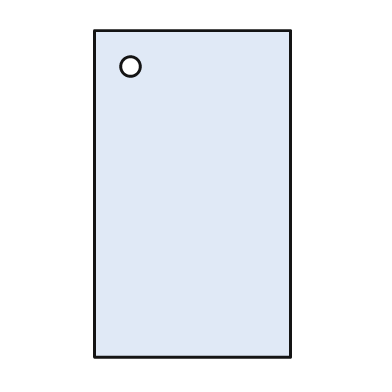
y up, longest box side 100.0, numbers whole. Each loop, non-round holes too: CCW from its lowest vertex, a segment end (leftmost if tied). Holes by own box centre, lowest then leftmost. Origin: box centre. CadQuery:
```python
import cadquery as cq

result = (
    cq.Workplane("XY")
    .moveTo(-30.0, -50.0)
    .lineTo(30.0, -50.0)
    .lineTo(30.0, 50.0)
    .lineTo(-30.0, 50.0)
    .close()
    .moveTo(-19.0, 39.0)
    .circle(3.0)
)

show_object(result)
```